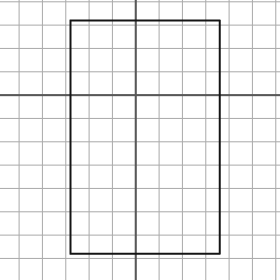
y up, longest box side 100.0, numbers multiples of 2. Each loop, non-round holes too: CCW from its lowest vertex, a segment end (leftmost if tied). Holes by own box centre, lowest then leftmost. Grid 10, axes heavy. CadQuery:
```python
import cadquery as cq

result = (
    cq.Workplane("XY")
    .moveTo(-28.0, -68.0)
    .lineTo(36.0, -68.0)
    .lineTo(36.0, 32.0)
    .lineTo(-28.0, 32.0)
    .close()
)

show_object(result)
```